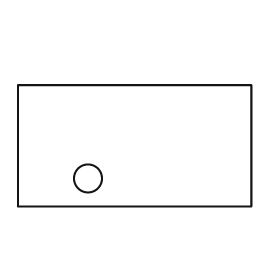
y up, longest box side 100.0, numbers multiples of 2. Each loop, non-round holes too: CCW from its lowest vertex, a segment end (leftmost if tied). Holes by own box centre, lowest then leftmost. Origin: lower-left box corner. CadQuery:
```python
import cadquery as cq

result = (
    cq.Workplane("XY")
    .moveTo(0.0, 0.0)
    .lineTo(100.0, 0.0)
    .lineTo(100.0, 52.0)
    .lineTo(0.0, 52.0)
    .close()
    .moveTo(30.0, 12.0)
    .circle(6.0)
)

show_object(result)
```